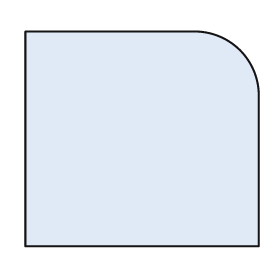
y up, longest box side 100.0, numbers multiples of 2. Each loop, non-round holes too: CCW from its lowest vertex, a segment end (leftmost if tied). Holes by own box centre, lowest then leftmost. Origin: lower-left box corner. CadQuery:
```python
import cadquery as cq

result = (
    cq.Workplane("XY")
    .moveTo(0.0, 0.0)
    .lineTo(100.0, 0.0)
    .lineTo(100.0, 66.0)
    .threePointArc((92.0, 84.0), (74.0, 92.0))
    .lineTo(0.0, 92.0)
    .close()
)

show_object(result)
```